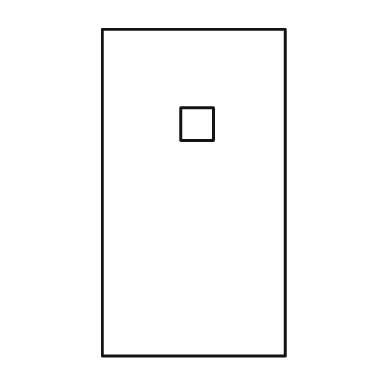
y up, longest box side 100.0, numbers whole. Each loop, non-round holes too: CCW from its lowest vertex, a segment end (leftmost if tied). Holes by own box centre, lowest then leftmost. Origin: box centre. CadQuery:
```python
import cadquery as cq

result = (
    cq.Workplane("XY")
    .moveTo(-28.0, -50.0)
    .lineTo(28.0, -50.0)
    .lineTo(28.0, 50.0)
    .lineTo(-28.0, 50.0)
    .close()
    .moveTo(-4.0, 16.0)
    .lineTo(6.0, 16.0)
    .lineTo(6.0, 26.0)
    .lineTo(-4.0, 26.0)
    .close()
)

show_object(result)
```